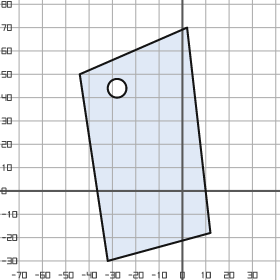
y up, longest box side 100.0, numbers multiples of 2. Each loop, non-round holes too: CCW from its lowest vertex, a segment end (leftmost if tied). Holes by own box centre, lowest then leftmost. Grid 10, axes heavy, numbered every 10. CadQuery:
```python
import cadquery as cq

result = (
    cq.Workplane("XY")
    .moveTo(-32.0, -30.0)
    .lineTo(12.0, -18.0)
    .lineTo(2.0, 70.0)
    .lineTo(-44.0, 50.0)
    .close()
    .moveTo(-28.0, 44.0)
    .circle(4.0)
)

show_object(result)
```